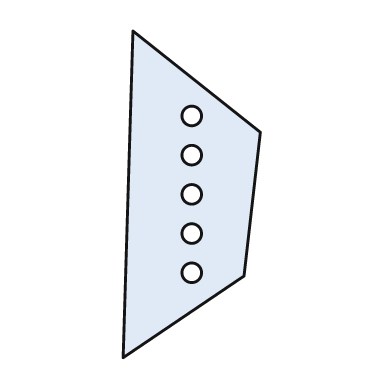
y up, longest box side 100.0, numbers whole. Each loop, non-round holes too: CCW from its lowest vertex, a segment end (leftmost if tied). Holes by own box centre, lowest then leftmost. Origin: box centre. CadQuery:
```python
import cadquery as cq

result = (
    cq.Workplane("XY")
    .moveTo(-21.0, -50.0)
    .lineTo(16.0, -25.0)
    .lineTo(21.0, 19.0)
    .lineTo(-18.0, 50.0)
    .close()
    .moveTo(0.0, -24.0)
    .circle(3.0)
    .moveTo(0.0, -12.0)
    .circle(3.0)
    .moveTo(0.0, 0.0)
    .circle(3.0)
    .moveTo(0.0, 12.0)
    .circle(3.0)
    .moveTo(0.0, 24.0)
    .circle(3.0)
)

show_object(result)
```